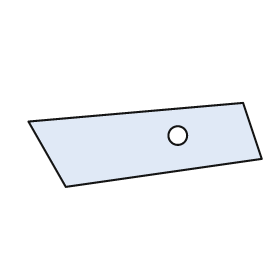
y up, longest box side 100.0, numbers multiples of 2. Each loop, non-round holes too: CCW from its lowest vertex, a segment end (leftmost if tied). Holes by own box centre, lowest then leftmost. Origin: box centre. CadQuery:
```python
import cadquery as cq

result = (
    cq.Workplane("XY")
    .moveTo(-34.0, -18.0)
    .lineTo(50.0, -6.0)
    .lineTo(42.0, 18.0)
    .lineTo(-50.0, 10.0)
    .close()
    .moveTo(14.0, 4.0)
    .circle(4.0)
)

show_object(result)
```